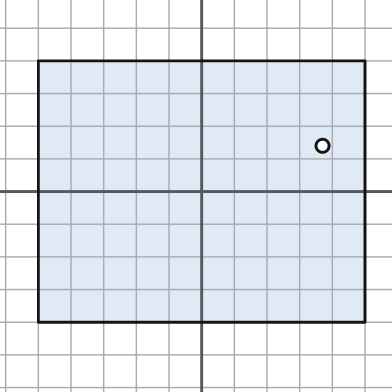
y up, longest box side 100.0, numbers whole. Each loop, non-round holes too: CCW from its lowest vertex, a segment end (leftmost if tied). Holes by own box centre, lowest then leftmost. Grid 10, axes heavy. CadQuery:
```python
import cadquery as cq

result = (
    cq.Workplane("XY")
    .moveTo(-50.0, -40.0)
    .lineTo(50.0, -40.0)
    .lineTo(50.0, 40.0)
    .lineTo(-50.0, 40.0)
    .close()
    .moveTo(37.0, 14.0)
    .circle(2.0)
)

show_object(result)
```